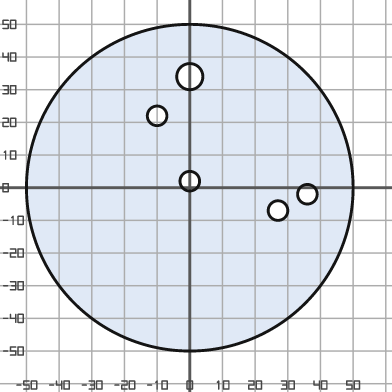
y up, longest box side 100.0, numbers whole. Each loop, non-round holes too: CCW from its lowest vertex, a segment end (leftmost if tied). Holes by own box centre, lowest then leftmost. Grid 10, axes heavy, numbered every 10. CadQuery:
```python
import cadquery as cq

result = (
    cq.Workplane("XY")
    .moveTo(0.0, 0.0)
    .circle(50.0)
    .moveTo(27.0, -7.0)
    .circle(3.0)
    .moveTo(36.0, -2.0)
    .circle(3.0)
    .moveTo(0.0, 2.0)
    .circle(3.0)
    .moveTo(-10.0, 22.0)
    .circle(3.0)
    .moveTo(0.0, 34.0)
    .circle(4.0)
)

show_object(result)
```